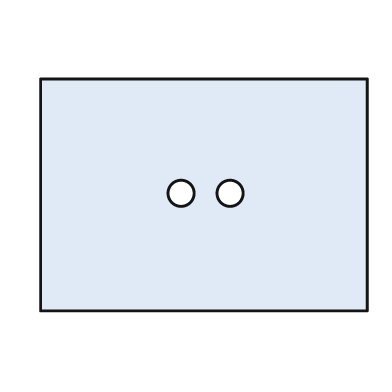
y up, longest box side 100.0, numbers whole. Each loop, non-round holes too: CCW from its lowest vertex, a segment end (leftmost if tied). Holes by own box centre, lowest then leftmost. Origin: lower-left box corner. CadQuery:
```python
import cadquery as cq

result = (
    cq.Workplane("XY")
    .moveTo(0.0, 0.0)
    .lineTo(100.0, 0.0)
    .lineTo(100.0, 71.0)
    .lineTo(0.0, 71.0)
    .close()
    .moveTo(43.0, 36.0)
    .circle(4.0)
    .moveTo(58.0, 36.0)
    .circle(4.0)
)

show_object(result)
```